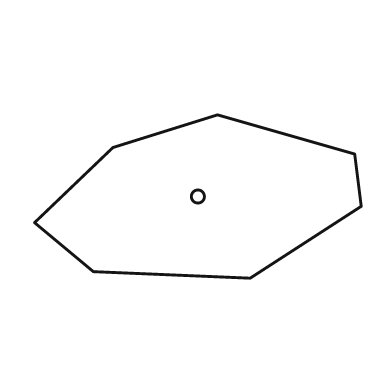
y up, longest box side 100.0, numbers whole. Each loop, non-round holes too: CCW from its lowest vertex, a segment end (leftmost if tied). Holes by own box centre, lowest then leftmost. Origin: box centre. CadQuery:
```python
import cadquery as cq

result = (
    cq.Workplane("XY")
    .moveTo(16.0, -25.0)
    .lineTo(50.0, -3.0)
    .lineTo(48.0, 13.0)
    .lineTo(6.0, 25.0)
    .lineTo(-26.0, 15.0)
    .lineTo(-50.0, -8.0)
    .lineTo(-32.0, -23.0)
    .close()
    .moveTo(0.0, 0.0)
    .circle(2.0)
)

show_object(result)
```